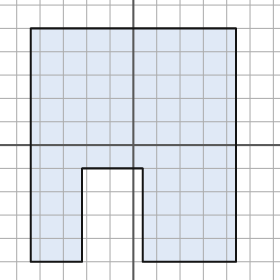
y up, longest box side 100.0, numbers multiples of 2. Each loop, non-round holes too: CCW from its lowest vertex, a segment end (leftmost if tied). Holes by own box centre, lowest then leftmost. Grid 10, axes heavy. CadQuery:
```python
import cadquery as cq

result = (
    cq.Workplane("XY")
    .moveTo(-44.0, -50.0)
    .lineTo(-22.0, -50.0)
    .lineTo(-22.0, -10.0)
    .lineTo(4.0, -10.0)
    .lineTo(4.0, -50.0)
    .lineTo(44.0, -50.0)
    .lineTo(44.0, 50.0)
    .lineTo(-44.0, 50.0)
    .close()
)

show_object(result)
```